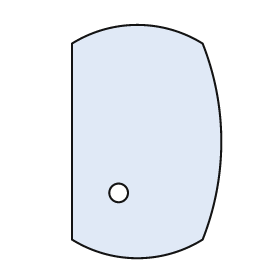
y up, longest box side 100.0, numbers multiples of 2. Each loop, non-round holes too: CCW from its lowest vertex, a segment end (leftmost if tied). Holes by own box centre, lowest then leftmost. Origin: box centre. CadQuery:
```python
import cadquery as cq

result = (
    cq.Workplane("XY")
    .moveTo(-32.0, -42.0)
    .threePointArc((-4.0, -50.0), (24.0, -42.0))
    .threePointArc((32.0, 0.0), (24.0, 42.0))
    .threePointArc((-4.0, 50.0), (-32.0, 42.0))
    .close()
    .moveTo(-12.0, -22.0)
    .circle(4.0)
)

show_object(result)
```